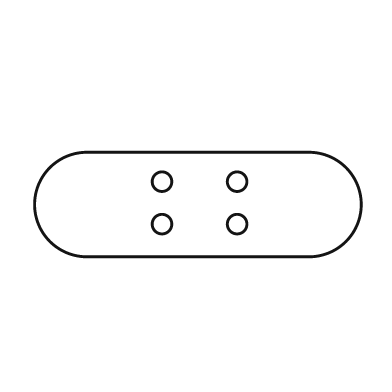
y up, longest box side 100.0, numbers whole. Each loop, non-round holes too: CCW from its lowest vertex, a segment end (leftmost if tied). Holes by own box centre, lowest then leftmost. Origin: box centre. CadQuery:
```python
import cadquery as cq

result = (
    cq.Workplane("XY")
    .moveTo(-34.0, -16.0)
    .lineTo(34.0, -16.0)
    .threePointArc((50.0, 0.0), (34.0, 16.0))
    .lineTo(-34.0, 16.0)
    .threePointArc((-50.0, 0.0), (-34.0, -16.0))
    .close()
    .moveTo(-11.0, -6.0)
    .circle(3.0)
    .moveTo(12.0, -6.0)
    .circle(3.0)
    .moveTo(-11.0, 7.0)
    .circle(3.0)
    .moveTo(12.0, 7.0)
    .circle(3.0)
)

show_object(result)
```